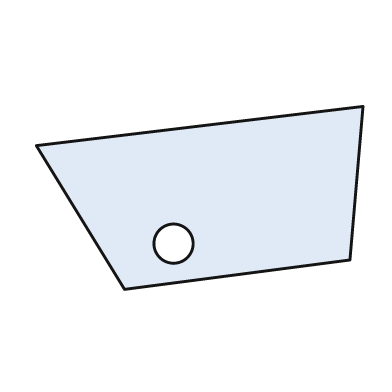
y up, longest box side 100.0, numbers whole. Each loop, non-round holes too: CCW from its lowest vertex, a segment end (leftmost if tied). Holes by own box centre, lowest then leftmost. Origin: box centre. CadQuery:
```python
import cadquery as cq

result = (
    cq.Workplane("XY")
    .moveTo(-23.0, -28.0)
    .lineTo(46.0, -19.0)
    .lineTo(50.0, 28.0)
    .lineTo(-50.0, 16.0)
    .close()
    .moveTo(-8.0, -14.0)
    .circle(6.0)
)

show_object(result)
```